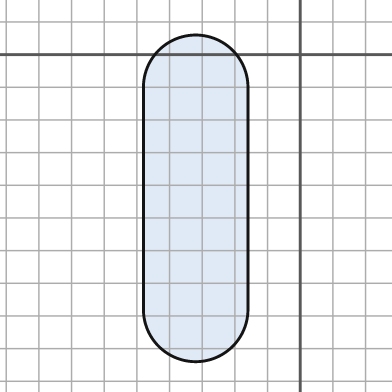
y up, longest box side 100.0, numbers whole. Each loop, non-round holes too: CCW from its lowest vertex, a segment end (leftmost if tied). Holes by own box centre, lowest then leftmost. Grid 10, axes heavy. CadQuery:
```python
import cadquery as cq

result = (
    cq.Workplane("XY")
    .moveTo(-48.0, -78.0)
    .threePointArc((-32.0, -94.0), (-16.0, -78.0))
    .lineTo(-16.0, -10.0)
    .threePointArc((-32.0, 6.0), (-48.0, -10.0))
    .close()
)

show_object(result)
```